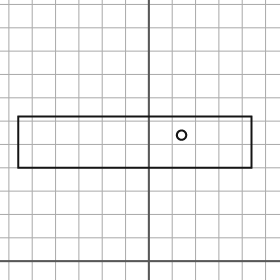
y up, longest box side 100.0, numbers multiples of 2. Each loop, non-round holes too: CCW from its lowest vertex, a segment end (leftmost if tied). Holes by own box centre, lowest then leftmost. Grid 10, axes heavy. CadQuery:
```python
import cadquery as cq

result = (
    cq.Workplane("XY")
    .moveTo(-56.0, 40.0)
    .lineTo(44.0, 40.0)
    .lineTo(44.0, 62.0)
    .lineTo(-56.0, 62.0)
    .close()
    .moveTo(14.0, 54.0)
    .circle(2.0)
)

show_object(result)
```